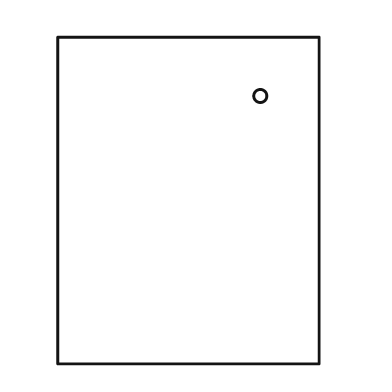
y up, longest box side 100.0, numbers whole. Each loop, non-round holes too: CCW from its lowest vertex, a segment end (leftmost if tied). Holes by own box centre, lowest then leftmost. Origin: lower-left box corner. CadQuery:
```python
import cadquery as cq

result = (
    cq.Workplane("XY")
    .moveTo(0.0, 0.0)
    .lineTo(80.0, 0.0)
    .lineTo(80.0, 100.0)
    .lineTo(0.0, 100.0)
    .close()
    .moveTo(62.0, 82.0)
    .circle(2.0)
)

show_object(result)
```